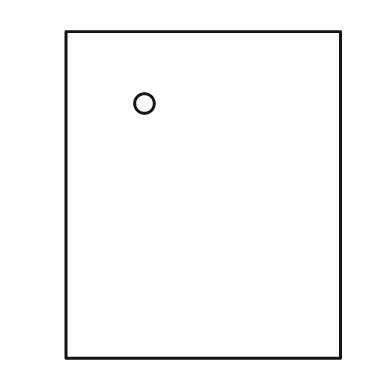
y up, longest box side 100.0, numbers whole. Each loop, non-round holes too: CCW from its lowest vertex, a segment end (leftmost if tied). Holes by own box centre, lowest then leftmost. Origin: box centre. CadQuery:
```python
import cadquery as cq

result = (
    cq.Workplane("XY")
    .moveTo(-42.0, -50.0)
    .lineTo(42.0, -50.0)
    .lineTo(42.0, 50.0)
    .lineTo(-42.0, 50.0)
    .close()
    .moveTo(-18.0, 28.0)
    .circle(3.0)
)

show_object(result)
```